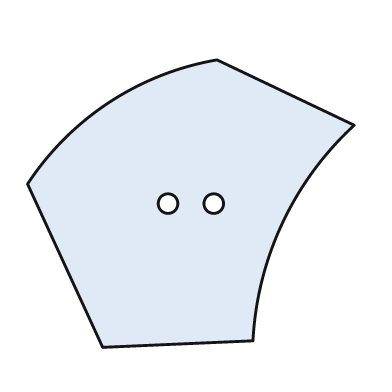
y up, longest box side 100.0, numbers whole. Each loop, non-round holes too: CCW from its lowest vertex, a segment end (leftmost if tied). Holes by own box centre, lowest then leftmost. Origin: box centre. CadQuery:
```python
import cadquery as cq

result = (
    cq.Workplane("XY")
    .moveTo(-27.0, -44.0)
    .lineTo(19.0, -42.0)
    .threePointArc((28.0, -6.0), (50.0, 24.0))
    .lineTo(8.0, 44.0)
    .threePointArc((-25.0, 31.0), (-50.0, 6.0))
    .close()
    .moveTo(-7.0, 0.0)
    .circle(3.0)
    .moveTo(7.0, 0.0)
    .circle(3.0)
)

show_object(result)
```